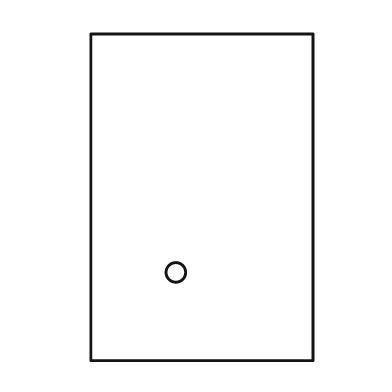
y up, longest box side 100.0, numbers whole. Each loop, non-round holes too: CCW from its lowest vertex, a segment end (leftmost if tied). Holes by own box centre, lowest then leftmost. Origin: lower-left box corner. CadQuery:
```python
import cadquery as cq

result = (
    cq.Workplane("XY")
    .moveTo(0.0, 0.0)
    .lineTo(68.0, 0.0)
    .lineTo(68.0, 100.0)
    .lineTo(0.0, 100.0)
    .close()
    .moveTo(26.0, 27.0)
    .circle(3.0)
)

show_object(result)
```